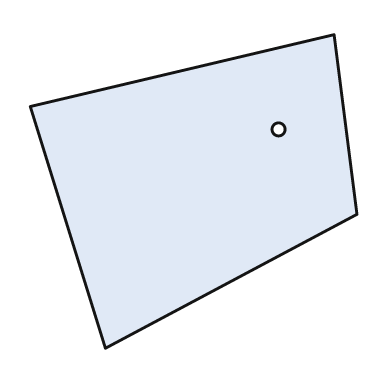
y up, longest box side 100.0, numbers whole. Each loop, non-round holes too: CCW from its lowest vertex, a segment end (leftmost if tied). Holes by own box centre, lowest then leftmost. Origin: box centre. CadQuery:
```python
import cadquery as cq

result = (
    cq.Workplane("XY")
    .moveTo(-27.0, -48.0)
    .lineTo(50.0, -7.0)
    .lineTo(43.0, 48.0)
    .lineTo(-50.0, 26.0)
    .close()
    .moveTo(26.0, 19.0)
    .circle(2.0)
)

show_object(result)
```